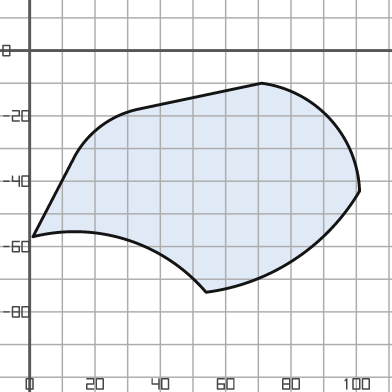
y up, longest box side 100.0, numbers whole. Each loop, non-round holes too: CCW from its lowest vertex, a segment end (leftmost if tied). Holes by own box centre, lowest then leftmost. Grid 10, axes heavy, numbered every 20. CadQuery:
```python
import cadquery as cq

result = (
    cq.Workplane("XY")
    .moveTo(54.0, -74.0)
    .threePointArc((81.0, -64.0), (101.0, -43.0))
    .threePointArc((92.0, -21.0), (71.0, -10.0))
    .lineTo(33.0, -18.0)
    .threePointArc((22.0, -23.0), (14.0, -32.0))
    .lineTo(1.0, -57.0)
    .threePointArc((30.0, -58.0), (54.0, -74.0))
    .close()
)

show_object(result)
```